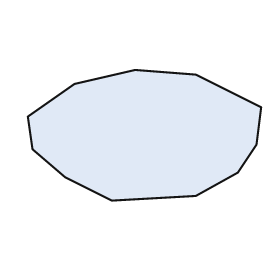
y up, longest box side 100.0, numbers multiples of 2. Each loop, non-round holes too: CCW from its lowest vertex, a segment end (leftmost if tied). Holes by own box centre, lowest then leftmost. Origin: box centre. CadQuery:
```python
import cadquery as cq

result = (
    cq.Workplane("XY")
    .moveTo(-14.0, -28.0)
    .lineTo(22.0, -26.0)
    .lineTo(40.0, -16.0)
    .lineTo(48.0, -4.0)
    .lineTo(50.0, 12.0)
    .lineTo(22.0, 26.0)
    .lineTo(-4.0, 28.0)
    .lineTo(-30.0, 22.0)
    .lineTo(-50.0, 8.0)
    .lineTo(-48.0, -6.0)
    .lineTo(-34.0, -18.0)
    .close()
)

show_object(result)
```